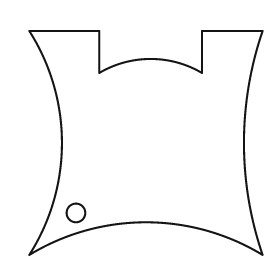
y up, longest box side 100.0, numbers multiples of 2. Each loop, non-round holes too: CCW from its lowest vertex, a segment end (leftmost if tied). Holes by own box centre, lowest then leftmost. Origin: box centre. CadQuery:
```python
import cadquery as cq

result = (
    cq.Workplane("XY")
    .moveTo(-50.0, -48.0)
    .threePointArc((0.0, -34.0), (50.0, -48.0))
    .threePointArc((42.0, 0.0), (50.0, 48.0))
    .lineTo(24.0, 48.0)
    .lineTo(24.0, 30.0)
    .threePointArc((2.0, 36.0), (-20.0, 30.0))
    .lineTo(-20.0, 48.0)
    .lineTo(-50.0, 48.0)
    .threePointArc((-36.0, 0.0), (-50.0, -48.0))
    .close()
    .moveTo(-30.0, -30.0)
    .circle(4.0)
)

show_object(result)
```